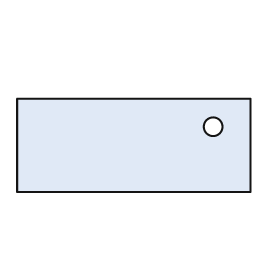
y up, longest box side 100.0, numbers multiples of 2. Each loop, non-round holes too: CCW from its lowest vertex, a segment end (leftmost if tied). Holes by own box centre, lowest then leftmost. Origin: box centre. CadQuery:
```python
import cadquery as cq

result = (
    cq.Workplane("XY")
    .moveTo(-50.0, -20.0)
    .lineTo(50.0, -20.0)
    .lineTo(50.0, 20.0)
    .lineTo(-50.0, 20.0)
    .close()
    .moveTo(34.0, 8.0)
    .circle(4.0)
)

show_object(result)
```